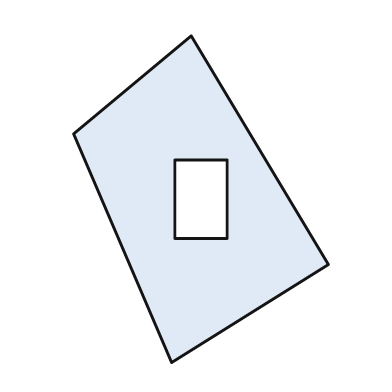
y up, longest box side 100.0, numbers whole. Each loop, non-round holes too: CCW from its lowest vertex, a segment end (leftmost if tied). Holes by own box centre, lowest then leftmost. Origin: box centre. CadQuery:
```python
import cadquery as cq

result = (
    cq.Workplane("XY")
    .moveTo(-9.0, -50.0)
    .lineTo(39.0, -20.0)
    .lineTo(-3.0, 50.0)
    .lineTo(-39.0, 20.0)
    .close()
    .moveTo(-8.0, -12.0)
    .lineTo(8.0, -12.0)
    .lineTo(8.0, 12.0)
    .lineTo(-8.0, 12.0)
    .close()
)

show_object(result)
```